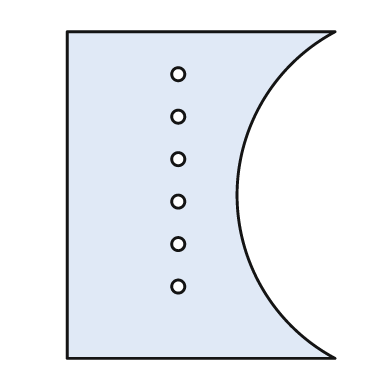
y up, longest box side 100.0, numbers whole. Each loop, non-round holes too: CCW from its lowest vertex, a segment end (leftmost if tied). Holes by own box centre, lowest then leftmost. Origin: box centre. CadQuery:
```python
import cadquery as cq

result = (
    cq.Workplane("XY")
    .moveTo(-41.0, -50.0)
    .lineTo(41.0, -50.0)
    .threePointArc((11.0, 0.0), (41.0, 50.0))
    .lineTo(-41.0, 50.0)
    .close()
    .moveTo(-7.0, -28.0)
    .circle(2.0)
    .moveTo(-7.0, -15.0)
    .circle(2.0)
    .moveTo(-7.0, -2.0)
    .circle(2.0)
    .moveTo(-7.0, 11.0)
    .circle(2.0)
    .moveTo(-7.0, 24.0)
    .circle(2.0)
    .moveTo(-7.0, 37.0)
    .circle(2.0)
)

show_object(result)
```